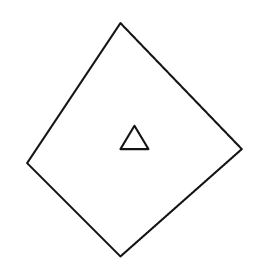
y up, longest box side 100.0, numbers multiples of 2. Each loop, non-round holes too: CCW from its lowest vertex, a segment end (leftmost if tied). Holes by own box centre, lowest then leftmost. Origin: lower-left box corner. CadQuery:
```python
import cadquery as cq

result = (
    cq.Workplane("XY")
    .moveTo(40.0, 0.0)
    .lineTo(92.0, 46.0)
    .lineTo(40.0, 100.0)
    .lineTo(0.0, 40.0)
    .close()
    .moveTo(40.0, 46.0)
    .lineTo(52.0, 46.0)
    .lineTo(46.0, 56.0)
    .close()
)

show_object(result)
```